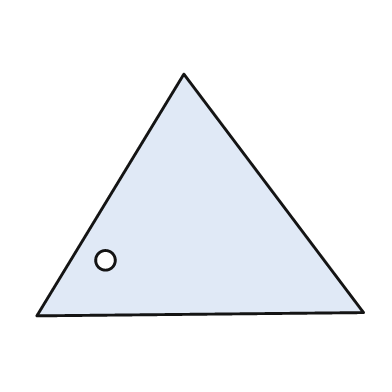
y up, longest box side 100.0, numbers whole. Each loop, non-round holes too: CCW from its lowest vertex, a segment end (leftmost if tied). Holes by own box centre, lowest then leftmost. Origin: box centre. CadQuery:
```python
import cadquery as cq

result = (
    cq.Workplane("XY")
    .moveTo(-50.0, -37.0)
    .lineTo(50.0, -36.0)
    .lineTo(-5.0, 37.0)
    .close()
    .moveTo(-29.0, -20.0)
    .circle(3.0)
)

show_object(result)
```